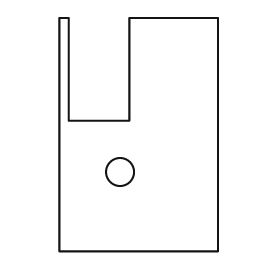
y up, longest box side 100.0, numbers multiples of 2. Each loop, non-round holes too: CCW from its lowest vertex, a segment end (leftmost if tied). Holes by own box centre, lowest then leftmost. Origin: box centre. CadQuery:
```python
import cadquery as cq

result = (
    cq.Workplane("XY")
    .moveTo(-34.0, -50.0)
    .lineTo(34.0, -50.0)
    .lineTo(34.0, 50.0)
    .lineTo(-4.0, 50.0)
    .lineTo(-4.0, 6.0)
    .lineTo(-30.0, 6.0)
    .lineTo(-30.0, 50.0)
    .lineTo(-34.0, 50.0)
    .close()
    .moveTo(-8.0, -16.0)
    .circle(6.0)
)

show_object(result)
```